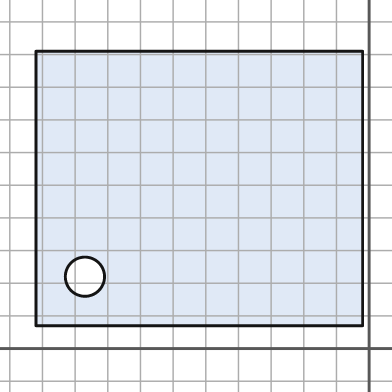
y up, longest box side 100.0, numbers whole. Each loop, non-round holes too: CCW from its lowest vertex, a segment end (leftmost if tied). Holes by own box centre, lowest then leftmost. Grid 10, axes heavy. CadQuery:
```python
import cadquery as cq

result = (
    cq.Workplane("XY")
    .moveTo(-102.0, 7.0)
    .lineTo(-2.0, 7.0)
    .lineTo(-2.0, 91.0)
    .lineTo(-102.0, 91.0)
    .close()
    .moveTo(-87.0, 22.0)
    .circle(6.0)
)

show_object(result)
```